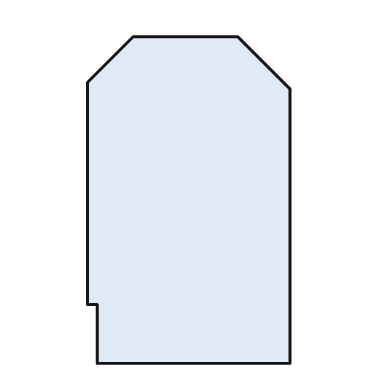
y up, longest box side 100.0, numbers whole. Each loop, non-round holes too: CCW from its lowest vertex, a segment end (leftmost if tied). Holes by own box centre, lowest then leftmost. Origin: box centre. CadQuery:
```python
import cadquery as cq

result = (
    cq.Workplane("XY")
    .moveTo(-28.0, -50.0)
    .lineTo(31.0, -50.0)
    .lineTo(31.0, 34.0)
    .lineTo(15.0, 50.0)
    .lineTo(-17.0, 50.0)
    .lineTo(-31.0, 36.0)
    .lineTo(-31.0, -32.0)
    .lineTo(-28.0, -32.0)
    .close()
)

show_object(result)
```